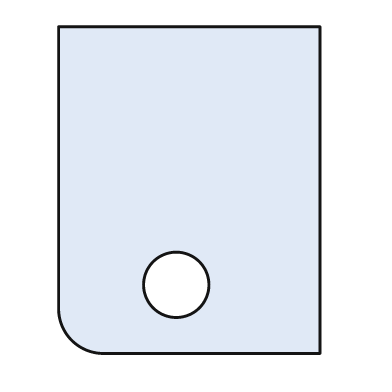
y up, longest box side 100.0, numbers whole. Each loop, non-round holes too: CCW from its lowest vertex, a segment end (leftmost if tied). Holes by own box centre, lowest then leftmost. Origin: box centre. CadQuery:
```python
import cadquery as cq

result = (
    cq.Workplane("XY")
    .moveTo(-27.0, -50.0)
    .lineTo(40.0, -50.0)
    .lineTo(40.0, 50.0)
    .lineTo(-40.0, 50.0)
    .lineTo(-40.0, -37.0)
    .threePointArc((-36.0, -46.0), (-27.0, -50.0))
    .close()
    .moveTo(-4.0, -29.0)
    .circle(10.0)
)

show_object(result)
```